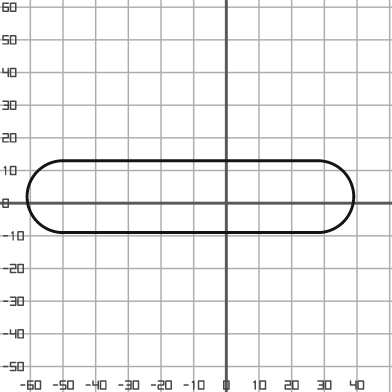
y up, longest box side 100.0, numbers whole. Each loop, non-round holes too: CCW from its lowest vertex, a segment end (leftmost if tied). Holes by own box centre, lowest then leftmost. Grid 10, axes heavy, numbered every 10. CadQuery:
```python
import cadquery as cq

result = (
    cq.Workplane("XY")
    .moveTo(-50.0, -9.0)
    .lineTo(28.0, -9.0)
    .threePointArc((39.0, 2.0), (28.0, 13.0))
    .lineTo(-50.0, 13.0)
    .threePointArc((-61.0, 2.0), (-50.0, -9.0))
    .close()
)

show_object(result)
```